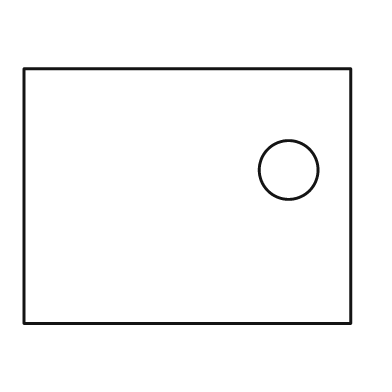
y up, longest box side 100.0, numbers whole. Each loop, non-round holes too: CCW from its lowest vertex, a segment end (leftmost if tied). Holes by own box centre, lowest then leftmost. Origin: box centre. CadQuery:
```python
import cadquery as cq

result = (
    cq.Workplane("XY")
    .moveTo(-50.0, -39.0)
    .lineTo(50.0, -39.0)
    .lineTo(50.0, 39.0)
    .lineTo(-50.0, 39.0)
    .close()
    .moveTo(31.0, 8.0)
    .circle(9.0)
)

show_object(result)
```